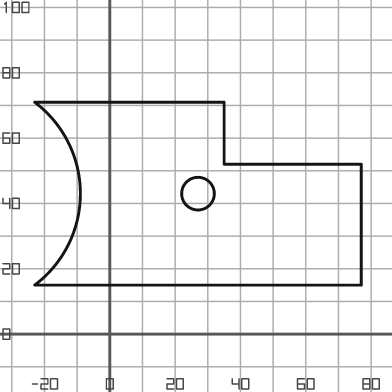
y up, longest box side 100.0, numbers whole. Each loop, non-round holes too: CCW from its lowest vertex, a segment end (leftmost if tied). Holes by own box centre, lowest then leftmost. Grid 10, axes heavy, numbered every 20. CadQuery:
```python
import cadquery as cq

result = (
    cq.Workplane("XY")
    .moveTo(-23.0, 15.0)
    .lineTo(77.0, 15.0)
    .lineTo(77.0, 52.0)
    .lineTo(35.0, 52.0)
    .lineTo(35.0, 71.0)
    .lineTo(-23.0, 71.0)
    .threePointArc((-9.0, 43.0), (-23.0, 15.0))
    .close()
    .moveTo(27.0, 43.0)
    .circle(5.0)
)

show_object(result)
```